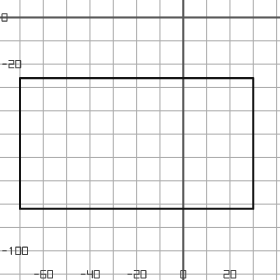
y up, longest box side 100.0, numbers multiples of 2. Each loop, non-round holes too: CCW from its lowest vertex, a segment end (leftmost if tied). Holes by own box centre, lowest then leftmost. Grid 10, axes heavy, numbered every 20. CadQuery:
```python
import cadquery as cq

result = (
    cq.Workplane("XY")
    .moveTo(-70.0, -82.0)
    .lineTo(30.0, -82.0)
    .lineTo(30.0, -26.0)
    .lineTo(-70.0, -26.0)
    .close()
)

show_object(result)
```